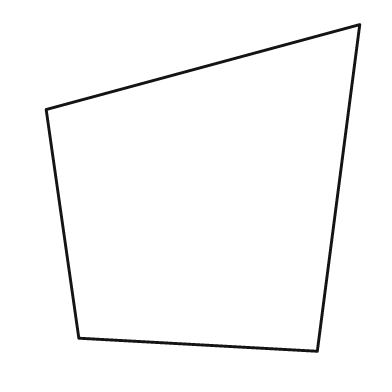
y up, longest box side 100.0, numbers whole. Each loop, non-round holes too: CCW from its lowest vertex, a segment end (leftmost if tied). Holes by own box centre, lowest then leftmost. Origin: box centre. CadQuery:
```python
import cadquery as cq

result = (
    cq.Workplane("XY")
    .moveTo(35.0, -50.0)
    .lineTo(48.0, 50.0)
    .lineTo(-48.0, 24.0)
    .lineTo(-38.0, -46.0)
    .close()
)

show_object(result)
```